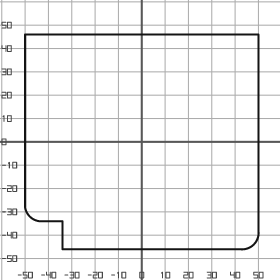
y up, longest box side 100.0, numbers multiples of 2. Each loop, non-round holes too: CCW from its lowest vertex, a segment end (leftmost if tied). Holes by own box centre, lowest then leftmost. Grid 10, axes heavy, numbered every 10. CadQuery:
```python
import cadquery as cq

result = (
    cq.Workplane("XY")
    .moveTo(-34.0, -46.0)
    .lineTo(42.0, -46.0)
    .threePointArc((48.0, -44.0), (50.0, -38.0))
    .lineTo(50.0, 46.0)
    .lineTo(-50.0, 46.0)
    .lineTo(-50.0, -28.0)
    .threePointArc((-48.0, -32.0), (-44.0, -34.0))
    .lineTo(-34.0, -34.0)
    .close()
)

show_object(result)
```